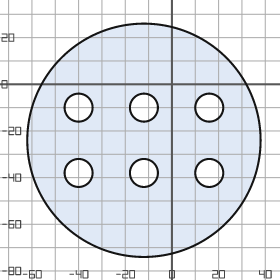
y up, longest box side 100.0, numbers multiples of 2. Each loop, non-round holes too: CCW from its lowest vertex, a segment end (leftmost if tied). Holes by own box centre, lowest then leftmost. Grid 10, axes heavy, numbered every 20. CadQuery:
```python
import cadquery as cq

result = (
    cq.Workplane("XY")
    .moveTo(-12.0, -24.0)
    .circle(50.0)
    .moveTo(-40.0, -38.0)
    .circle(6.0)
    .moveTo(-12.0, -38.0)
    .circle(6.0)
    .moveTo(16.0, -38.0)
    .circle(6.0)
    .moveTo(-40.0, -10.0)
    .circle(6.0)
    .moveTo(-12.0, -10.0)
    .circle(6.0)
    .moveTo(16.0, -10.0)
    .circle(6.0)
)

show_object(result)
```